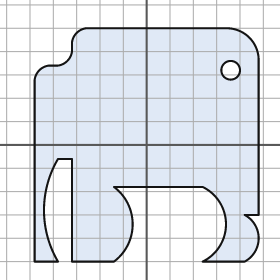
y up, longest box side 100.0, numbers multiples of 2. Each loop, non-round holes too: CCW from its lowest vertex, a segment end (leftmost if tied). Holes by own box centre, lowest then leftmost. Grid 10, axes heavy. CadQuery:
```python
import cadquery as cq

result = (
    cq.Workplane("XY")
    .moveTo(-48.0, -50.0)
    .lineTo(-38.0, -50.0)
    .threePointArc((-44.0, -28.0), (-38.0, -6.0))
    .lineTo(-32.0, -6.0)
    .lineTo(-32.0, -50.0)
    .lineTo(-14.0, -50.0)
    .threePointArc((-6.0, -34.0), (-14.0, -18.0))
    .lineTo(24.0, -18.0)
    .threePointArc((34.0, -34.0), (24.0, -50.0))
    .lineTo(42.0, -50.0)
    .threePointArc((48.0, -40.0), (42.0, -30.0))
    .lineTo(48.0, -30.0)
    .lineTo(48.0, 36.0)
    .threePointArc((44.0, 46.0), (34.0, 50.0))
    .lineTo(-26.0, 50.0)
    .threePointArc((-30.0, 48.0), (-32.0, 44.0))
    .lineTo(-32.0, 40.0)
    .threePointArc((-34.0, 36.0), (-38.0, 34.0))
    .lineTo(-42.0, 34.0)
    .threePointArc((-46.0, 32.0), (-48.0, 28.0))
    .close()
    .moveTo(36.0, 32.0)
    .circle(4.0)
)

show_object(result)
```